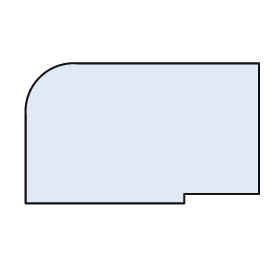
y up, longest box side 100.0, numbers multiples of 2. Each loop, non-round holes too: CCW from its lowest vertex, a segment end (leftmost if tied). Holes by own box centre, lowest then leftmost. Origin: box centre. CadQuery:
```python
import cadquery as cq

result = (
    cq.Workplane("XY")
    .moveTo(-50.0, -30.0)
    .lineTo(18.0, -30.0)
    .lineTo(18.0, -26.0)
    .lineTo(50.0, -26.0)
    .lineTo(50.0, 30.0)
    .lineTo(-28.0, 30.0)
    .threePointArc((-44.0, 24.0), (-50.0, 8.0))
    .close()
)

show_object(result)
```